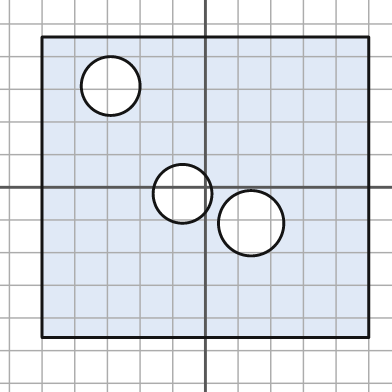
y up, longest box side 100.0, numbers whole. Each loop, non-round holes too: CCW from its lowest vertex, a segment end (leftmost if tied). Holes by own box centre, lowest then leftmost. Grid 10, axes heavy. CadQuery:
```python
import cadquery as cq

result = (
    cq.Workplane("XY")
    .moveTo(-50.0, -46.0)
    .lineTo(50.0, -46.0)
    .lineTo(50.0, 46.0)
    .lineTo(-50.0, 46.0)
    .close()
    .moveTo(14.0, -11.0)
    .circle(10.0)
    .moveTo(-7.0, -2.0)
    .circle(9.0)
    .moveTo(-29.0, 31.0)
    .circle(9.0)
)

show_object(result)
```